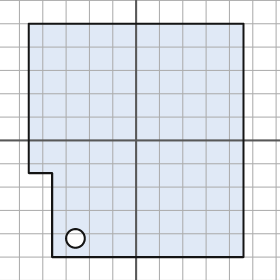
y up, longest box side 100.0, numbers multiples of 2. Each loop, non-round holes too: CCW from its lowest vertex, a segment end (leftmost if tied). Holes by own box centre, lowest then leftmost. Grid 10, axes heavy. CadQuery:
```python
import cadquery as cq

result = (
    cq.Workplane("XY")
    .moveTo(-36.0, -50.0)
    .lineTo(46.0, -50.0)
    .lineTo(46.0, 50.0)
    .lineTo(-46.0, 50.0)
    .lineTo(-46.0, -14.0)
    .lineTo(-36.0, -14.0)
    .close()
    .moveTo(-26.0, -42.0)
    .circle(4.0)
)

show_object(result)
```